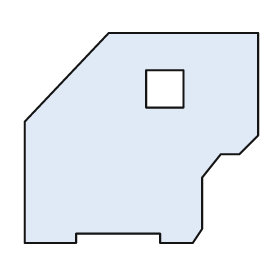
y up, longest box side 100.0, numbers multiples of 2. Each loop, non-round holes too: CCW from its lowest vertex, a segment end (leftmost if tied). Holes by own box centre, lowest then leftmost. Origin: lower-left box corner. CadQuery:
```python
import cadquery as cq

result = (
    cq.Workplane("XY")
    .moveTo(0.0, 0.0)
    .lineTo(22.0, 0.0)
    .lineTo(22.0, 4.0)
    .lineTo(58.0, 4.0)
    .lineTo(58.0, 0.0)
    .lineTo(72.0, 0.0)
    .lineTo(76.0, 6.0)
    .lineTo(76.0, 28.0)
    .lineTo(84.0, 38.0)
    .lineTo(92.0, 38.0)
    .lineTo(100.0, 46.0)
    .lineTo(100.0, 90.0)
    .lineTo(36.0, 90.0)
    .lineTo(0.0, 52.0)
    .close()
    .moveTo(52.0, 58.0)
    .lineTo(68.0, 58.0)
    .lineTo(68.0, 74.0)
    .lineTo(52.0, 74.0)
    .close()
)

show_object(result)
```